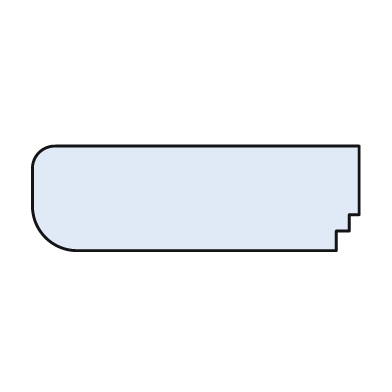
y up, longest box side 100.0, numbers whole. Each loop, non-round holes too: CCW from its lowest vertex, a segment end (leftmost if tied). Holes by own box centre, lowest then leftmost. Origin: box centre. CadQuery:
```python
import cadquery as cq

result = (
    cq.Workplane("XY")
    .moveTo(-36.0, -16.0)
    .lineTo(43.0, -16.0)
    .lineTo(43.0, -10.0)
    .lineTo(47.0, -10.0)
    .lineTo(47.0, -5.0)
    .lineTo(50.0, -5.0)
    .lineTo(50.0, 16.0)
    .lineTo(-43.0, 16.0)
    .threePointArc((-48.0, 14.0), (-50.0, 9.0))
    .lineTo(-50.0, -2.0)
    .threePointArc((-46.0, -12.0), (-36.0, -16.0))
    .close()
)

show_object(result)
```